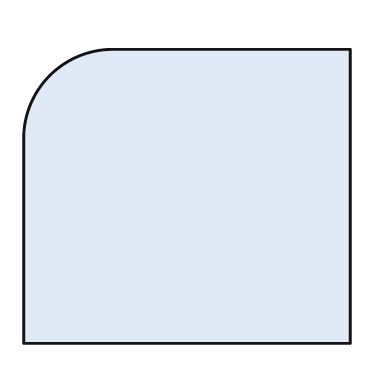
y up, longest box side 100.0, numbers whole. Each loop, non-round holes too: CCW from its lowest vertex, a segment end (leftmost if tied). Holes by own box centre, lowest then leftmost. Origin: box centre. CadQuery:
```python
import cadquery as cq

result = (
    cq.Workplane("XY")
    .moveTo(-50.0, -45.0)
    .lineTo(50.0, -45.0)
    .lineTo(50.0, 45.0)
    .lineTo(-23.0, 45.0)
    .threePointArc((-42.0, 37.0), (-50.0, 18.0))
    .close()
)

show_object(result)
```